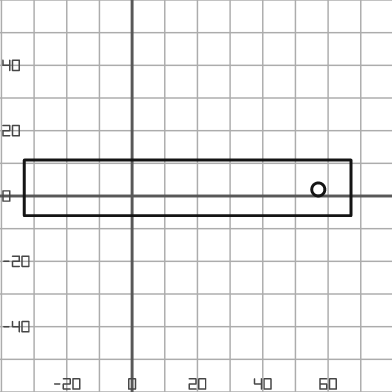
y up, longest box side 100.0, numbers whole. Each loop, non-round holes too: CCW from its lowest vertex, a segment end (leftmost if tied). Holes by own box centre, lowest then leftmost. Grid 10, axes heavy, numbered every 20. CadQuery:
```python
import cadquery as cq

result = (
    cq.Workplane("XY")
    .moveTo(-33.0, -6.0)
    .lineTo(67.0, -6.0)
    .lineTo(67.0, 11.0)
    .lineTo(-33.0, 11.0)
    .close()
    .moveTo(57.0, 2.0)
    .circle(2.0)
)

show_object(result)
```